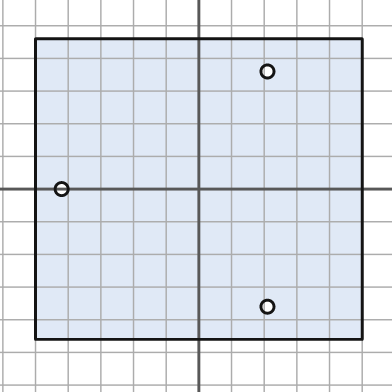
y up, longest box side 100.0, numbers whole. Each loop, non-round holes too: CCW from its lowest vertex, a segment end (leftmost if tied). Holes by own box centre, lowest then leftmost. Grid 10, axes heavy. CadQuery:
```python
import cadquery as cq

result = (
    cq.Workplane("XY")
    .moveTo(-50.0, -46.0)
    .lineTo(50.0, -46.0)
    .lineTo(50.0, 46.0)
    .lineTo(-50.0, 46.0)
    .close()
    .moveTo(21.0, -36.0)
    .circle(2.0)
    .moveTo(-42.0, 0.0)
    .circle(2.0)
    .moveTo(21.0, 36.0)
    .circle(2.0)
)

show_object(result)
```